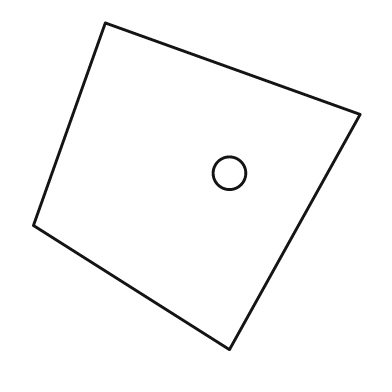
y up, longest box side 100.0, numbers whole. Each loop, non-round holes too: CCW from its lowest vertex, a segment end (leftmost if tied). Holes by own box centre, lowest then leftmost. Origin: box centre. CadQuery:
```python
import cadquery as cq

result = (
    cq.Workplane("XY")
    .moveTo(10.0, -50.0)
    .lineTo(50.0, 22.0)
    .lineTo(-28.0, 50.0)
    .lineTo(-50.0, -12.0)
    .close()
    .moveTo(10.0, 4.0)
    .circle(5.0)
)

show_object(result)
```